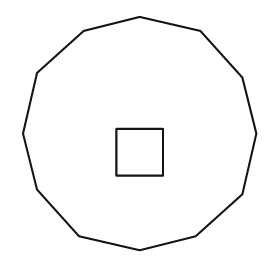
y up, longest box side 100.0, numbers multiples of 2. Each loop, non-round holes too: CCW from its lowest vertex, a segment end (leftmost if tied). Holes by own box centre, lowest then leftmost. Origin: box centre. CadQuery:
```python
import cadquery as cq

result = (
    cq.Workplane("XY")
    .moveTo(0.0, -50.0)
    .lineTo(24.0, -44.0)
    .lineTo(44.0, -26.0)
    .lineTo(50.0, 0.0)
    .lineTo(44.0, 24.0)
    .lineTo(26.0, 44.0)
    .lineTo(0.0, 50.0)
    .lineTo(-24.0, 44.0)
    .lineTo(-44.0, 26.0)
    .lineTo(-50.0, 0.0)
    .lineTo(-44.0, -24.0)
    .lineTo(-26.0, -44.0)
    .close()
    .moveTo(-10.0, -18.0)
    .lineTo(10.0, -18.0)
    .lineTo(10.0, 2.0)
    .lineTo(-10.0, 2.0)
    .close()
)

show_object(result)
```